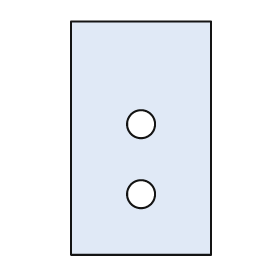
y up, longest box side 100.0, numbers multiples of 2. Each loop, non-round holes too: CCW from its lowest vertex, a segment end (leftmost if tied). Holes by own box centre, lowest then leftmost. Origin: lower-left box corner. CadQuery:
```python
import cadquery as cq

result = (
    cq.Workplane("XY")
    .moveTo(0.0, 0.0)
    .lineTo(60.0, 0.0)
    .lineTo(60.0, 100.0)
    .lineTo(0.0, 100.0)
    .close()
    .moveTo(30.0, 26.0)
    .circle(6.0)
    .moveTo(30.0, 56.0)
    .circle(6.0)
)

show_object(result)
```